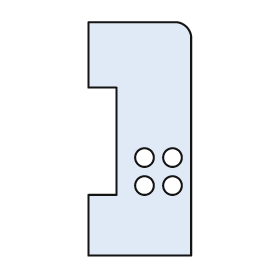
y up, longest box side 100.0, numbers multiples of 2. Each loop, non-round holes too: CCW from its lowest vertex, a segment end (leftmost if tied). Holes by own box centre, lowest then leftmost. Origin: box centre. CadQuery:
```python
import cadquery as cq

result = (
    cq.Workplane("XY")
    .moveTo(-22.0, -50.0)
    .lineTo(22.0, -50.0)
    .lineTo(22.0, 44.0)
    .threePointArc((20.0, 48.0), (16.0, 50.0))
    .lineTo(-22.0, 50.0)
    .lineTo(-22.0, 22.0)
    .lineTo(-10.0, 22.0)
    .lineTo(-10.0, -24.0)
    .lineTo(-22.0, -24.0)
    .close()
    .moveTo(2.0, -20.0)
    .circle(4.0)
    .moveTo(14.0, -20.0)
    .circle(4.0)
    .moveTo(2.0, -8.0)
    .circle(4.0)
    .moveTo(14.0, -8.0)
    .circle(4.0)
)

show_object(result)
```